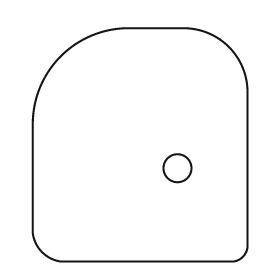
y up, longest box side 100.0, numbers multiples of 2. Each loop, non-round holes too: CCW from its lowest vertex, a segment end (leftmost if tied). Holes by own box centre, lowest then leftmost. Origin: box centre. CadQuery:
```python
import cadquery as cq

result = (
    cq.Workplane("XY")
    .moveTo(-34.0, -50.0)
    .lineTo(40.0, -50.0)
    .threePointArc((44.0, -48.0), (46.0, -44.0))
    .lineTo(46.0, 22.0)
    .threePointArc((38.0, 42.0), (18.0, 50.0))
    .lineTo(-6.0, 50.0)
    .threePointArc((-34.0, 38.0), (-46.0, 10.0))
    .lineTo(-46.0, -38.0)
    .threePointArc((-42.0, -46.0), (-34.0, -50.0))
    .close()
    .moveTo(16.0, -10.0)
    .circle(6.0)
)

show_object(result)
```